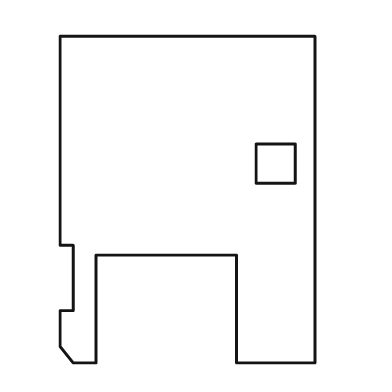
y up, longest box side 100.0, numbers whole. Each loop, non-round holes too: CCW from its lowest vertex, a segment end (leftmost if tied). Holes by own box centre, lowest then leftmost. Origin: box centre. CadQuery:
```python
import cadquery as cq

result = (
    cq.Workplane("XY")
    .moveTo(-35.0, -50.0)
    .lineTo(-28.0, -50.0)
    .lineTo(-28.0, -17.0)
    .lineTo(15.0, -17.0)
    .lineTo(15.0, -50.0)
    .lineTo(39.0, -50.0)
    .lineTo(39.0, 50.0)
    .lineTo(-39.0, 50.0)
    .lineTo(-39.0, -14.0)
    .lineTo(-35.0, -14.0)
    .lineTo(-35.0, -34.0)
    .lineTo(-39.0, -34.0)
    .lineTo(-39.0, -45.0)
    .close()
    .moveTo(21.0, 5.0)
    .lineTo(33.0, 5.0)
    .lineTo(33.0, 17.0)
    .lineTo(21.0, 17.0)
    .close()
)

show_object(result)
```